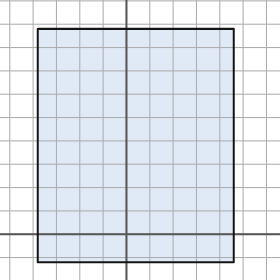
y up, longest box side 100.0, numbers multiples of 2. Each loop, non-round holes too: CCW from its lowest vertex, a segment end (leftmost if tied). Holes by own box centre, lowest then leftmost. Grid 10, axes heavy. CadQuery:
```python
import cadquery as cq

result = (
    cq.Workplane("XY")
    .moveTo(-38.0, -12.0)
    .lineTo(46.0, -12.0)
    .lineTo(46.0, 88.0)
    .lineTo(-38.0, 88.0)
    .close()
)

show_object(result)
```